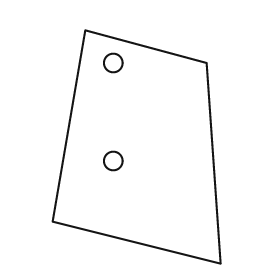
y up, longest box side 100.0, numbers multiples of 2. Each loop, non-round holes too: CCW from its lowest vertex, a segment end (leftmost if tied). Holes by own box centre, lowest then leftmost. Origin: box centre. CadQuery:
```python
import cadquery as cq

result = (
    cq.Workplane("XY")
    .moveTo(36.0, -50.0)
    .lineTo(30.0, 36.0)
    .lineTo(-22.0, 50.0)
    .lineTo(-36.0, -32.0)
    .close()
    .moveTo(-10.0, -6.0)
    .circle(4.0)
    .moveTo(-10.0, 36.0)
    .circle(4.0)
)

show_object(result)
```